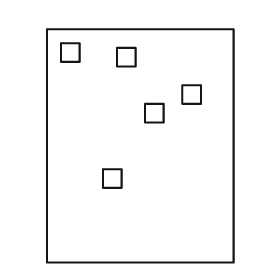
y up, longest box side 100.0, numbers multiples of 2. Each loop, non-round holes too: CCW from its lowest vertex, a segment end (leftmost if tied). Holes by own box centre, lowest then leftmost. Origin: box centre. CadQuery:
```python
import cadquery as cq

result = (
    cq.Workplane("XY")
    .moveTo(-40.0, -50.0)
    .lineTo(40.0, -50.0)
    .lineTo(40.0, 50.0)
    .lineTo(-40.0, 50.0)
    .close()
    .moveTo(-16.0, -18.0)
    .lineTo(-8.0, -18.0)
    .lineTo(-8.0, -10.0)
    .lineTo(-16.0, -10.0)
    .close()
    .moveTo(2.0, 10.0)
    .lineTo(10.0, 10.0)
    .lineTo(10.0, 18.0)
    .lineTo(2.0, 18.0)
    .close()
    .moveTo(18.0, 18.0)
    .lineTo(26.0, 18.0)
    .lineTo(26.0, 26.0)
    .lineTo(18.0, 26.0)
    .close()
    .moveTo(-10.0, 34.0)
    .lineTo(-2.0, 34.0)
    .lineTo(-2.0, 42.0)
    .lineTo(-10.0, 42.0)
    .close()
    .moveTo(-34.0, 36.0)
    .lineTo(-26.0, 36.0)
    .lineTo(-26.0, 44.0)
    .lineTo(-34.0, 44.0)
    .close()
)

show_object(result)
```